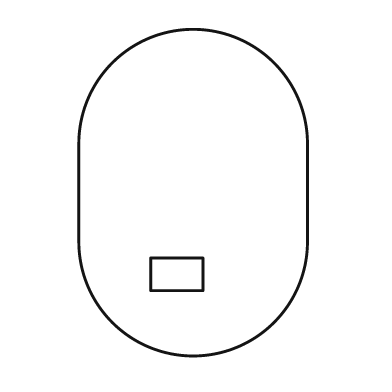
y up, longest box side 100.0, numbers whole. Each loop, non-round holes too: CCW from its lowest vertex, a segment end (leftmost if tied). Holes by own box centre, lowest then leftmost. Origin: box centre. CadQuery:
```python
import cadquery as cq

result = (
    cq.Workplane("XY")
    .moveTo(-35.0, -15.0)
    .threePointArc((0.0, -50.0), (35.0, -15.0))
    .lineTo(35.0, 15.0)
    .threePointArc((0.0, 50.0), (-35.0, 15.0))
    .close()
    .moveTo(-13.0, -30.0)
    .lineTo(3.0, -30.0)
    .lineTo(3.0, -20.0)
    .lineTo(-13.0, -20.0)
    .close()
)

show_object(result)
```